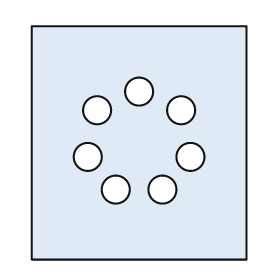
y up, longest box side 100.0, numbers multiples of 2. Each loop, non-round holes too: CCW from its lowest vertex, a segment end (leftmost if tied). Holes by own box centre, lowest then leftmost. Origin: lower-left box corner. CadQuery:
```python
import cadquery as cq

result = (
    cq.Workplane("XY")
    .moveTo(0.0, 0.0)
    .lineTo(92.0, 0.0)
    .lineTo(92.0, 100.0)
    .lineTo(0.0, 100.0)
    .close()
    .moveTo(36.0, 30.0)
    .circle(6.0)
    .moveTo(56.0, 30.0)
    .circle(6.0)
    .moveTo(24.0, 44.0)
    .circle(6.0)
    .moveTo(68.0, 44.0)
    .circle(6.0)
    .moveTo(28.0, 64.0)
    .circle(6.0)
    .moveTo(64.0, 64.0)
    .circle(6.0)
    .moveTo(46.0, 72.0)
    .circle(6.0)
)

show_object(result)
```